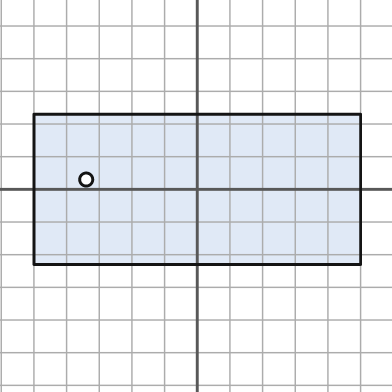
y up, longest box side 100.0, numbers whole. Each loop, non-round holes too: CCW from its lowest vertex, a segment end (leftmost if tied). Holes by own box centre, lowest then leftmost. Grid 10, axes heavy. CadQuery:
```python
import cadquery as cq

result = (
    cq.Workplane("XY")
    .moveTo(-50.0, -23.0)
    .lineTo(50.0, -23.0)
    .lineTo(50.0, 23.0)
    .lineTo(-50.0, 23.0)
    .close()
    .moveTo(-34.0, 3.0)
    .circle(2.0)
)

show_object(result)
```